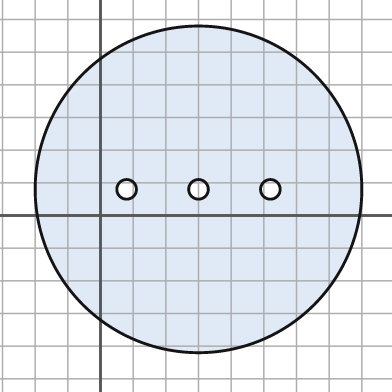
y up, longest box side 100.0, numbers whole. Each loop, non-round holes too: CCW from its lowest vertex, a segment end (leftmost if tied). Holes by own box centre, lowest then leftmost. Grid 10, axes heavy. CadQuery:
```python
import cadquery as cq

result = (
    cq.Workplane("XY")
    .moveTo(30.0, 8.0)
    .circle(50.0)
    .moveTo(8.0, 8.0)
    .circle(3.0)
    .moveTo(30.0, 8.0)
    .circle(3.0)
    .moveTo(52.0, 8.0)
    .circle(3.0)
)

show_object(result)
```